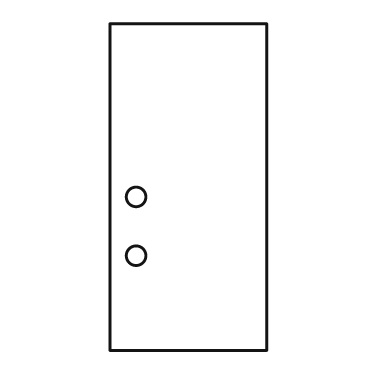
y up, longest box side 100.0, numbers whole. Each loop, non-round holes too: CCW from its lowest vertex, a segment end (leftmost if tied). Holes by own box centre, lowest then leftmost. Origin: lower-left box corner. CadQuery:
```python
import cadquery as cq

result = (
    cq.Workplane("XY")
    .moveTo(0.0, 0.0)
    .lineTo(48.0, 0.0)
    .lineTo(48.0, 100.0)
    .lineTo(0.0, 100.0)
    .close()
    .moveTo(8.0, 29.0)
    .circle(3.0)
    .moveTo(8.0, 47.0)
    .circle(3.0)
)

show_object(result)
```